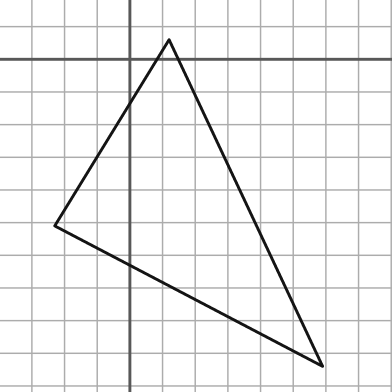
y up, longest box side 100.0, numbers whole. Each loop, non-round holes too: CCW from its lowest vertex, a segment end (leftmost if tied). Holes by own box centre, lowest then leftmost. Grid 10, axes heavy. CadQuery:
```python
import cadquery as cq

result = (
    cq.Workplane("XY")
    .moveTo(59.0, -94.0)
    .lineTo(12.0, 6.0)
    .lineTo(-23.0, -51.0)
    .close()
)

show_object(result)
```